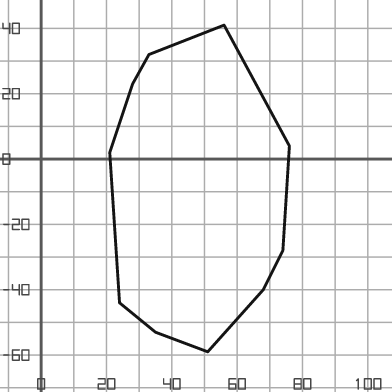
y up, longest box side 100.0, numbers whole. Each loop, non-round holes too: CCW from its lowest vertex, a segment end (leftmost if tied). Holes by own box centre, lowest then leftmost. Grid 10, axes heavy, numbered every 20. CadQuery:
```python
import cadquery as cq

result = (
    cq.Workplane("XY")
    .moveTo(51.0, -59.0)
    .lineTo(68.0, -40.0)
    .lineTo(74.0, -28.0)
    .lineTo(76.0, 4.0)
    .lineTo(56.0, 41.0)
    .lineTo(33.0, 32.0)
    .lineTo(28.0, 23.0)
    .lineTo(21.0, 2.0)
    .lineTo(24.0, -44.0)
    .lineTo(35.0, -53.0)
    .close()
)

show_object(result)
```